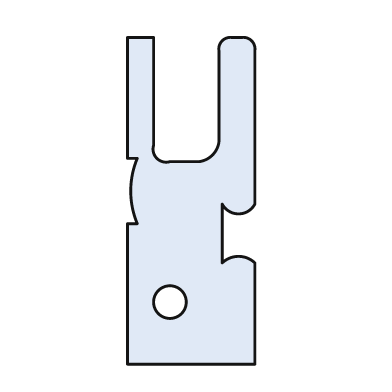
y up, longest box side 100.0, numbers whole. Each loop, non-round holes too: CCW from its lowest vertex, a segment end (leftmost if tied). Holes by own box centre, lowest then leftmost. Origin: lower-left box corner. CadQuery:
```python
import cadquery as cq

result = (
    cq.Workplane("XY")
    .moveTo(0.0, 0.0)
    .lineTo(39.0, 0.0)
    .lineTo(39.0, 31.0)
    .threePointArc((34.0, 33.0), (29.0, 31.0))
    .lineTo(29.0, 49.0)
    .threePointArc((34.0, 46.0), (39.0, 49.0))
    .lineTo(39.0, 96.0)
    .threePointArc((38.0, 99.0), (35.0, 100.0))
    .lineTo(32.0, 100.0)
    .threePointArc((29.0, 99.0), (28.0, 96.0))
    .lineTo(28.0, 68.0)
    .threePointArc((26.0, 64.0), (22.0, 62.0))
    .lineTo(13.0, 62.0)
    .threePointArc((9.0, 63.0), (8.0, 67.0))
    .lineTo(8.0, 100.0)
    .lineTo(0.0, 100.0)
    .lineTo(0.0, 63.0)
    .lineTo(3.0, 63.0)
    .threePointArc((1.0, 53.0), (3.0, 43.0))
    .lineTo(0.0, 43.0)
    .close()
    .moveTo(13.0, 19.0)
    .circle(5.0)
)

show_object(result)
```